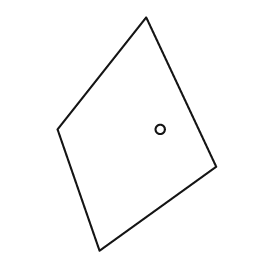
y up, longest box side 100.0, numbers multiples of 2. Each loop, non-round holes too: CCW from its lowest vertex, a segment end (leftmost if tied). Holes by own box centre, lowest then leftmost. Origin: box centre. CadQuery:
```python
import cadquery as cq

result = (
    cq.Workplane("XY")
    .moveTo(-16.0, -50.0)
    .lineTo(34.0, -14.0)
    .lineTo(4.0, 50.0)
    .lineTo(-34.0, 2.0)
    .close()
    .moveTo(10.0, 2.0)
    .circle(2.0)
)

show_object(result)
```